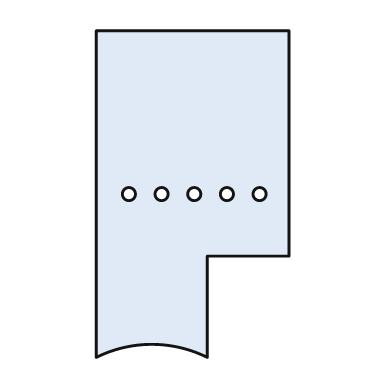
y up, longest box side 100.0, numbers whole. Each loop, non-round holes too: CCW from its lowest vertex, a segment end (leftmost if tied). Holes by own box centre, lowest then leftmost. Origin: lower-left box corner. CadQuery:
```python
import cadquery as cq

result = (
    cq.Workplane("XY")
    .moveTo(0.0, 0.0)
    .threePointArc((17.0, 4.0), (34.0, 0.0))
    .lineTo(34.0, 31.0)
    .lineTo(59.0, 31.0)
    .lineTo(59.0, 100.0)
    .lineTo(0.0, 100.0)
    .close()
    .moveTo(10.0, 50.0)
    .circle(2.0)
    .moveTo(20.0, 50.0)
    .circle(2.0)
    .moveTo(30.0, 50.0)
    .circle(2.0)
    .moveTo(40.0, 50.0)
    .circle(2.0)
    .moveTo(50.0, 50.0)
    .circle(2.0)
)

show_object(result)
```